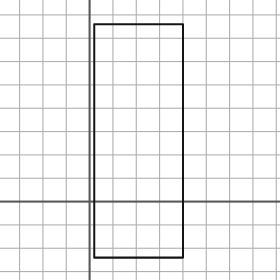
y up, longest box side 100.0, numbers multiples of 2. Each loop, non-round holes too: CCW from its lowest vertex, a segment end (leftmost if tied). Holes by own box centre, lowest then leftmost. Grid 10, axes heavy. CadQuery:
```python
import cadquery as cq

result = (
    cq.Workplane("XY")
    .moveTo(2.0, -24.0)
    .lineTo(40.0, -24.0)
    .lineTo(40.0, 76.0)
    .lineTo(2.0, 76.0)
    .close()
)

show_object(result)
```